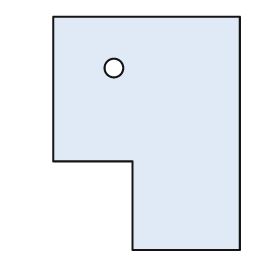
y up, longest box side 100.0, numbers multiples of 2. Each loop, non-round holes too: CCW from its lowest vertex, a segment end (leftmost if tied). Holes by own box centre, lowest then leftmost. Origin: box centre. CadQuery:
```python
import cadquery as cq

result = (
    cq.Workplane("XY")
    .moveTo(-6.0, -50.0)
    .lineTo(40.0, -50.0)
    .lineTo(40.0, 50.0)
    .lineTo(-40.0, 50.0)
    .lineTo(-40.0, -12.0)
    .lineTo(-6.0, -12.0)
    .close()
    .moveTo(-14.0, 28.0)
    .circle(4.0)
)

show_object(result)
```